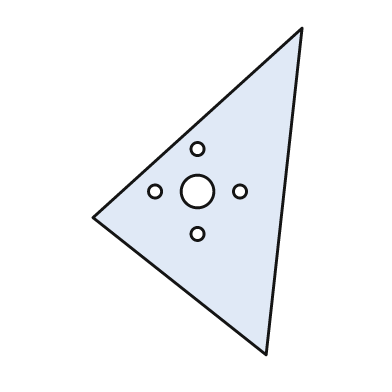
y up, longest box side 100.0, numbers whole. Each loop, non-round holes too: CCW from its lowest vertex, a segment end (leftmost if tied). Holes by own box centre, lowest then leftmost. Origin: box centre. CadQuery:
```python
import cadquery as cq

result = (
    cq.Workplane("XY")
    .moveTo(21.0, -50.0)
    .lineTo(32.0, 50.0)
    .lineTo(-32.0, -8.0)
    .close()
    .moveTo(0.0, -13.0)
    .circle(2.0)
    .moveTo(-13.0, 0.0)
    .circle(2.0)
    .moveTo(0.0, 0.0)
    .circle(5.0)
    .moveTo(13.0, 0.0)
    .circle(2.0)
    .moveTo(0.0, 13.0)
    .circle(2.0)
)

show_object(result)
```